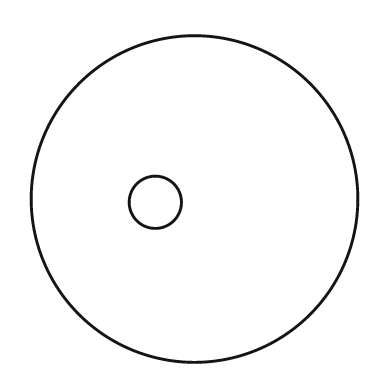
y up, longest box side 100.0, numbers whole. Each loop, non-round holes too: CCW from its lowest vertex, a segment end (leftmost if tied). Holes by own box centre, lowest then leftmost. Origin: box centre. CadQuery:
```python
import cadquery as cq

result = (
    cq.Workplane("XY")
    .moveTo(0.0, 0.0)
    .circle(50.0)
    .moveTo(-12.0, -1.0)
    .circle(8.0)
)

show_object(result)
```